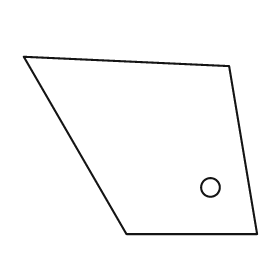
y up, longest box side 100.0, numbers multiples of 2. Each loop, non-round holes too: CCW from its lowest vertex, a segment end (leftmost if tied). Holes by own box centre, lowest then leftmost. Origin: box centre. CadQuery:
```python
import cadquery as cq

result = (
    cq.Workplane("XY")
    .moveTo(-6.0, -38.0)
    .lineTo(50.0, -38.0)
    .lineTo(38.0, 34.0)
    .lineTo(-50.0, 38.0)
    .close()
    .moveTo(30.0, -18.0)
    .circle(4.0)
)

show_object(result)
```